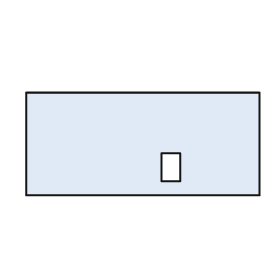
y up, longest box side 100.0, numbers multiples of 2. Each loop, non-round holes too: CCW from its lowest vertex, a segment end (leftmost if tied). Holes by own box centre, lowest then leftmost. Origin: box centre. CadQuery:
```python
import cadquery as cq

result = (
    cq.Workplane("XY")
    .moveTo(-50.0, -22.0)
    .lineTo(50.0, -22.0)
    .lineTo(50.0, 22.0)
    .lineTo(-50.0, 22.0)
    .close()
    .moveTo(8.0, -16.0)
    .lineTo(16.0, -16.0)
    .lineTo(16.0, -4.0)
    .lineTo(8.0, -4.0)
    .close()
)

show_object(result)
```